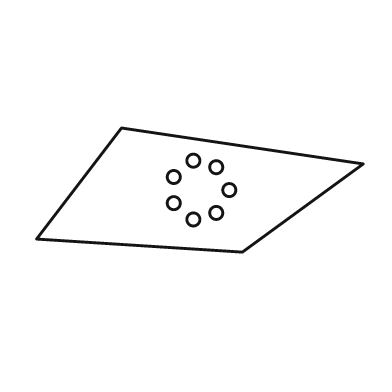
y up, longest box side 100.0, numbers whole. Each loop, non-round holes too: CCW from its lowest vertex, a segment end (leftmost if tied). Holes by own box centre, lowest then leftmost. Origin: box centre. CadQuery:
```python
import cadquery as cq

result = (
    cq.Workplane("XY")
    .moveTo(13.0, -19.0)
    .lineTo(50.0, 8.0)
    .lineTo(-24.0, 19.0)
    .lineTo(-50.0, -15.0)
    .close()
    .moveTo(-2.0, -9.0)
    .circle(2.0)
    .moveTo(5.0, -7.0)
    .circle(2.0)
    .moveTo(-8.0, -4.0)
    .circle(2.0)
    .moveTo(9.0, 0.0)
    .circle(2.0)
    .moveTo(-8.0, 4.0)
    .circle(2.0)
    .moveTo(5.0, 7.0)
    .circle(2.0)
    .moveTo(-2.0, 9.0)
    .circle(2.0)
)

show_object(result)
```